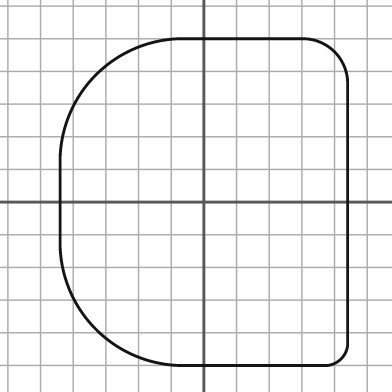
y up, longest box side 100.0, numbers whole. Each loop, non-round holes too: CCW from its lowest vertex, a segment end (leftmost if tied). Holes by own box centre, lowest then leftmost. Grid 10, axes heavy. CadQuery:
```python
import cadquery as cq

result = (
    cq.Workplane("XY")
    .moveTo(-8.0, -50.0)
    .lineTo(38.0, -50.0)
    .threePointArc((42.0, -48.0), (44.0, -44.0))
    .lineTo(44.0, 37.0)
    .threePointArc((40.0, 46.0), (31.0, 50.0))
    .lineTo(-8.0, 50.0)
    .threePointArc((-33.0, 39.0), (-44.0, 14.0))
    .lineTo(-44.0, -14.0)
    .threePointArc((-33.0, -39.0), (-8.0, -50.0))
    .close()
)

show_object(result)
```